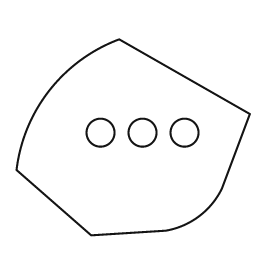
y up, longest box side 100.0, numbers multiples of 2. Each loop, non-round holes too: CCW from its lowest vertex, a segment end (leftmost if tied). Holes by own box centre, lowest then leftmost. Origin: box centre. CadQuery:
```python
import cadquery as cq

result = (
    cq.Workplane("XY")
    .moveTo(-18.0, -42.0)
    .lineTo(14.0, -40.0)
    .threePointArc((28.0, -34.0), (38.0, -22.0))
    .lineTo(50.0, 10.0)
    .lineTo(-6.0, 42.0)
    .threePointArc((-36.0, 20.0), (-50.0, -14.0))
    .close()
    .moveTo(-14.0, 2.0)
    .circle(6.0)
    .moveTo(4.0, 2.0)
    .circle(6.0)
    .moveTo(22.0, 2.0)
    .circle(6.0)
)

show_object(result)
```